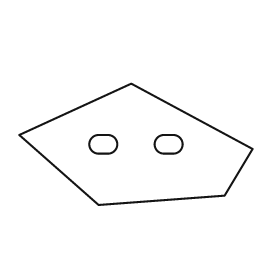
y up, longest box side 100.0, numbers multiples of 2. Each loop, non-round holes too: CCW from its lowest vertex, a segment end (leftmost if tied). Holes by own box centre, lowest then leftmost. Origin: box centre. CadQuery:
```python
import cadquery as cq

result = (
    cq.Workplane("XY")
    .moveTo(-16.0, -26.0)
    .lineTo(38.0, -22.0)
    .lineTo(50.0, -2.0)
    .lineTo(-2.0, 26.0)
    .lineTo(-50.0, 4.0)
    .close()
    .moveTo(-16.0, -4.0)
    .lineTo(-12.0, -4.0)
    .threePointArc((-8.0, 0.0), (-12.0, 4.0))
    .lineTo(-16.0, 4.0)
    .threePointArc((-20.0, 0.0), (-16.0, -4.0))
    .close()
    .moveTo(12.0, -4.0)
    .lineTo(16.0, -4.0)
    .threePointArc((20.0, 0.0), (16.0, 4.0))
    .lineTo(12.0, 4.0)
    .threePointArc((8.0, 0.0), (12.0, -4.0))
    .close()
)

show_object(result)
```